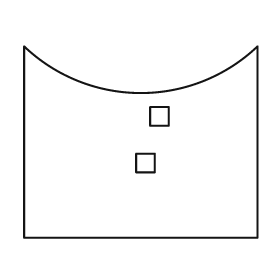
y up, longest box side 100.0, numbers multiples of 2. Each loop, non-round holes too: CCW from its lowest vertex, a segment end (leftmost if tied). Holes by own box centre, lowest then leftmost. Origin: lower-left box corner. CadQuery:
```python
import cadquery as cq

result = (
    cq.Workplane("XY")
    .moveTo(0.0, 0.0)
    .lineTo(100.0, 0.0)
    .lineTo(100.0, 82.0)
    .threePointArc((50.0, 62.0), (0.0, 82.0))
    .close()
    .moveTo(48.0, 28.0)
    .lineTo(56.0, 28.0)
    .lineTo(56.0, 36.0)
    .lineTo(48.0, 36.0)
    .close()
    .moveTo(54.0, 48.0)
    .lineTo(62.0, 48.0)
    .lineTo(62.0, 56.0)
    .lineTo(54.0, 56.0)
    .close()
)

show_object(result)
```